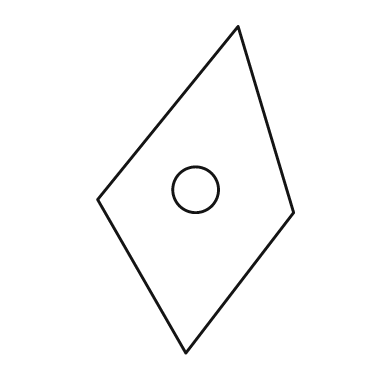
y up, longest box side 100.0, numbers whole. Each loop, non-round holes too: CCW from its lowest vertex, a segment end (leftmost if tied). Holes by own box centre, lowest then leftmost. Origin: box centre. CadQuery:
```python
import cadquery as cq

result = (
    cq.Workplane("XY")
    .moveTo(-3.0, -50.0)
    .lineTo(30.0, -7.0)
    .lineTo(13.0, 50.0)
    .lineTo(-30.0, -3.0)
    .close()
    .moveTo(0.0, 0.0)
    .circle(7.0)
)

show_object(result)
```